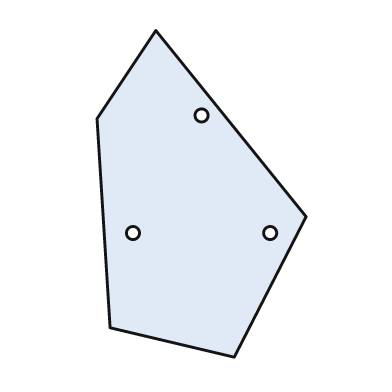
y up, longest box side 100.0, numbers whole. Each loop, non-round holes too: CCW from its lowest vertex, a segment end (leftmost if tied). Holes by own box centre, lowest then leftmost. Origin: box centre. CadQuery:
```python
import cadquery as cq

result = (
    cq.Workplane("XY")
    .moveTo(10.0, -50.0)
    .lineTo(32.0, -7.0)
    .lineTo(-14.0, 50.0)
    .lineTo(-32.0, 23.0)
    .lineTo(-28.0, -41.0)
    .close()
    .moveTo(-21.0, -12.0)
    .circle(2.0)
    .moveTo(21.0, -12.0)
    .circle(2.0)
    .moveTo(0.0, 24.0)
    .circle(2.0)
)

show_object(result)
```